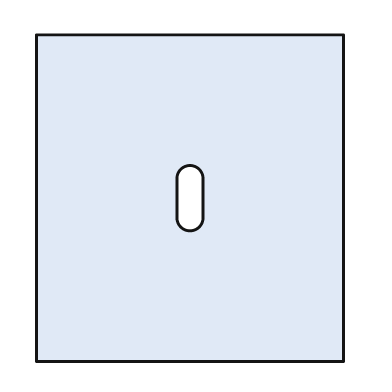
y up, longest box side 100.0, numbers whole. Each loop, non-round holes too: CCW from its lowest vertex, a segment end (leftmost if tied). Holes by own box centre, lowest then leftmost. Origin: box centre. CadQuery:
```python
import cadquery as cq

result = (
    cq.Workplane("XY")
    .moveTo(-47.0, -50.0)
    .lineTo(47.0, -50.0)
    .lineTo(47.0, 50.0)
    .lineTo(-47.0, 50.0)
    .close()
    .moveTo(-4.0, -6.0)
    .threePointArc((0.0, -10.0), (4.0, -6.0))
    .lineTo(4.0, 6.0)
    .threePointArc((0.0, 10.0), (-4.0, 6.0))
    .close()
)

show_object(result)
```